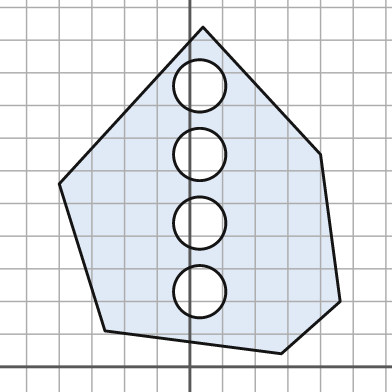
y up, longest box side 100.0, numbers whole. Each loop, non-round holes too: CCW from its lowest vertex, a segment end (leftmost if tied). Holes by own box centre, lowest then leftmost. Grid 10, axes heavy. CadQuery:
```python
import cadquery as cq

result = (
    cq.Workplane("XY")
    .moveTo(28.0, 4.0)
    .lineTo(46.0, 20.0)
    .lineTo(40.0, 65.0)
    .lineTo(4.0, 104.0)
    .lineTo(-40.0, 56.0)
    .lineTo(-26.0, 11.0)
    .close()
    .moveTo(3.0, 23.0)
    .circle(8.0)
    .moveTo(3.0, 44.0)
    .circle(8.0)
    .moveTo(3.0, 65.0)
    .circle(8.0)
    .moveTo(3.0, 86.0)
    .circle(8.0)
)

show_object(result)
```